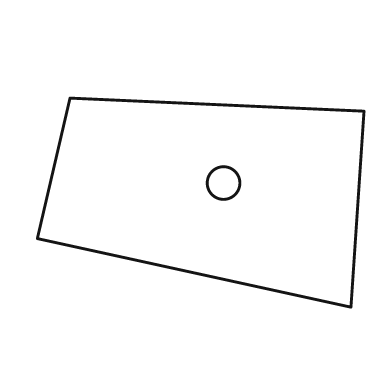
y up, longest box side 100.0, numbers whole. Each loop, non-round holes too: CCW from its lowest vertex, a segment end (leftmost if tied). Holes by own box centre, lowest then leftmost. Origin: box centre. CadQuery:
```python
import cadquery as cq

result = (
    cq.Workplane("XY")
    .moveTo(46.0, -32.0)
    .lineTo(50.0, 28.0)
    .lineTo(-40.0, 32.0)
    .lineTo(-50.0, -11.0)
    .close()
    .moveTo(7.0, 6.0)
    .circle(5.0)
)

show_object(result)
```